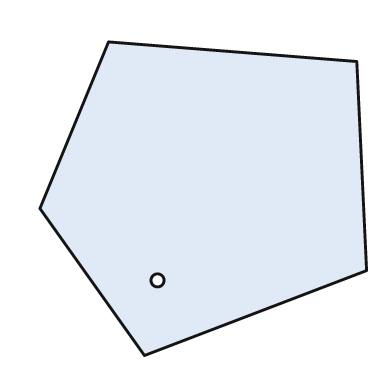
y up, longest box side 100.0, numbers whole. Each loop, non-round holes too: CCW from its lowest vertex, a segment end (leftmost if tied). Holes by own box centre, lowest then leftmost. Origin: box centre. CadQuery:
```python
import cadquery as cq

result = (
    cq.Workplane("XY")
    .moveTo(-18.0, -48.0)
    .lineTo(50.0, -22.0)
    .lineTo(47.0, 42.0)
    .lineTo(-29.0, 48.0)
    .lineTo(-50.0, -3.0)
    .close()
    .moveTo(-14.0, -25.0)
    .circle(2.0)
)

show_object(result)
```